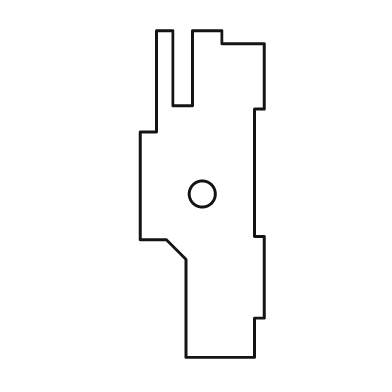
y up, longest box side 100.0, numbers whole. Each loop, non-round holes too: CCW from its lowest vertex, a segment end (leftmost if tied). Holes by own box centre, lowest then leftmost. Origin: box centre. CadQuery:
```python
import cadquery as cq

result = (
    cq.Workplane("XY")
    .moveTo(-5.0, -50.0)
    .lineTo(16.0, -50.0)
    .lineTo(16.0, -38.0)
    .lineTo(19.0, -38.0)
    .lineTo(19.0, -13.0)
    .lineTo(16.0, -13.0)
    .lineTo(16.0, 26.0)
    .lineTo(19.0, 26.0)
    .lineTo(19.0, 46.0)
    .lineTo(6.0, 46.0)
    .lineTo(6.0, 50.0)
    .lineTo(-3.0, 50.0)
    .lineTo(-3.0, 27.0)
    .lineTo(-9.0, 27.0)
    .lineTo(-9.0, 50.0)
    .lineTo(-14.0, 50.0)
    .lineTo(-14.0, 19.0)
    .lineTo(-19.0, 19.0)
    .lineTo(-19.0, -14.0)
    .lineTo(-11.0, -14.0)
    .lineTo(-5.0, -20.0)
    .close()
    .moveTo(0.0, 0.0)
    .circle(4.0)
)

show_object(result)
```